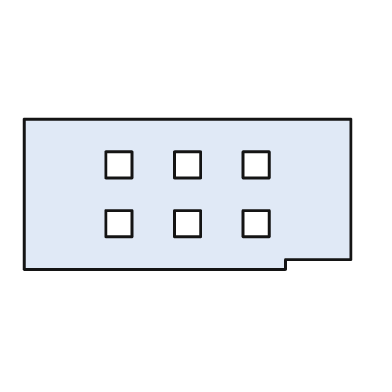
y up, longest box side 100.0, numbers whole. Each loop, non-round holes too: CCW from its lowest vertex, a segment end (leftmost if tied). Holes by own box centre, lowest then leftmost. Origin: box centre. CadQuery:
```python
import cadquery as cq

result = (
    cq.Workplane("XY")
    .moveTo(-50.0, -23.0)
    .lineTo(30.0, -23.0)
    .lineTo(30.0, -20.0)
    .lineTo(50.0, -20.0)
    .lineTo(50.0, 23.0)
    .lineTo(-50.0, 23.0)
    .close()
    .moveTo(-25.0, -13.0)
    .lineTo(-17.0, -13.0)
    .lineTo(-17.0, -5.0)
    .lineTo(-25.0, -5.0)
    .close()
    .moveTo(-4.0, -13.0)
    .lineTo(4.0, -13.0)
    .lineTo(4.0, -5.0)
    .lineTo(-4.0, -5.0)
    .close()
    .moveTo(17.0, -13.0)
    .lineTo(25.0, -13.0)
    .lineTo(25.0, -5.0)
    .lineTo(17.0, -5.0)
    .close()
    .moveTo(-25.0, 5.0)
    .lineTo(-17.0, 5.0)
    .lineTo(-17.0, 13.0)
    .lineTo(-25.0, 13.0)
    .close()
    .moveTo(-4.0, 5.0)
    .lineTo(4.0, 5.0)
    .lineTo(4.0, 13.0)
    .lineTo(-4.0, 13.0)
    .close()
    .moveTo(17.0, 5.0)
    .lineTo(25.0, 5.0)
    .lineTo(25.0, 13.0)
    .lineTo(17.0, 13.0)
    .close()
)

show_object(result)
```